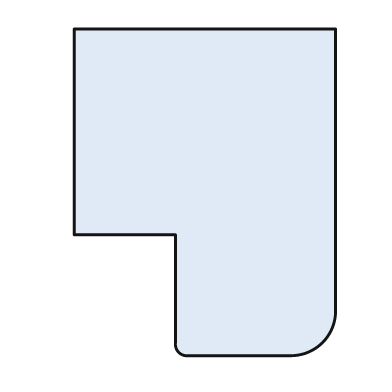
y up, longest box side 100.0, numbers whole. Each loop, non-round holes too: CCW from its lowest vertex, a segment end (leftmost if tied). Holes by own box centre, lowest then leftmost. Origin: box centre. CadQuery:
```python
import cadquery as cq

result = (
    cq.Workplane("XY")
    .moveTo(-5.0, -50.0)
    .lineTo(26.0, -50.0)
    .threePointArc((36.0, -46.0), (40.0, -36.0))
    .lineTo(40.0, 50.0)
    .lineTo(-40.0, 50.0)
    .lineTo(-40.0, -13.0)
    .lineTo(-9.0, -13.0)
    .lineTo(-9.0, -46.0)
    .threePointArc((-8.0, -49.0), (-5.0, -50.0))
    .close()
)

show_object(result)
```